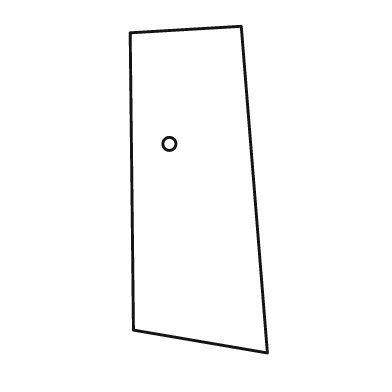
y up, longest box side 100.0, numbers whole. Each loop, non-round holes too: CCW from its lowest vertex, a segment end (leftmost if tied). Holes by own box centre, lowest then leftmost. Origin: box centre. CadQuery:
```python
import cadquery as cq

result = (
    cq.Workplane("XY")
    .moveTo(21.0, -50.0)
    .lineTo(13.0, 50.0)
    .lineTo(-21.0, 48.0)
    .lineTo(-20.0, -43.0)
    .close()
    .moveTo(-9.0, 14.0)
    .circle(2.0)
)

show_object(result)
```